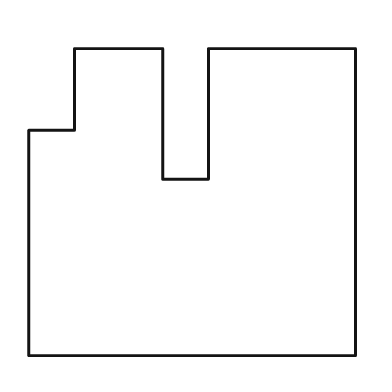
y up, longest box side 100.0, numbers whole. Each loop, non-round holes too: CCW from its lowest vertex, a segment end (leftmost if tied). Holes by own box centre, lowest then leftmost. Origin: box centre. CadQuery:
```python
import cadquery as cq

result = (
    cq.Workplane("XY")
    .moveTo(-50.0, -47.0)
    .lineTo(50.0, -47.0)
    .lineTo(50.0, 47.0)
    .lineTo(5.0, 47.0)
    .lineTo(5.0, 7.0)
    .lineTo(-9.0, 7.0)
    .lineTo(-9.0, 47.0)
    .lineTo(-36.0, 47.0)
    .lineTo(-36.0, 22.0)
    .lineTo(-50.0, 22.0)
    .close()
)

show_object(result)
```